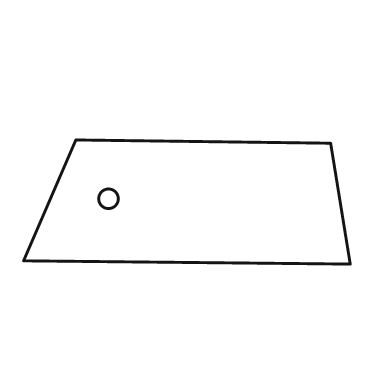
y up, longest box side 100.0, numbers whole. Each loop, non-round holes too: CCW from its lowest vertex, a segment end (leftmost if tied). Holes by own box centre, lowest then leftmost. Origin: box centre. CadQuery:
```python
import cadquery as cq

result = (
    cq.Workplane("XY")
    .moveTo(50.0, -19.0)
    .lineTo(44.0, 18.0)
    .lineTo(-34.0, 19.0)
    .lineTo(-50.0, -18.0)
    .close()
    .moveTo(-24.0, 1.0)
    .circle(3.0)
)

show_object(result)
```